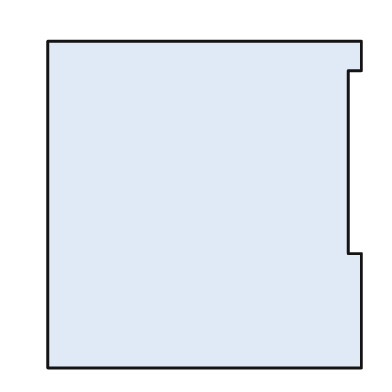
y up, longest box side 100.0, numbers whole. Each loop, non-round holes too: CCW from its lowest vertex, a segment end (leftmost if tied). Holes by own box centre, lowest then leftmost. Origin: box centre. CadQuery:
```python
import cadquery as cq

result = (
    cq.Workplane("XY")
    .moveTo(-48.0, -50.0)
    .lineTo(48.0, -50.0)
    .lineTo(48.0, -15.0)
    .lineTo(44.0, -15.0)
    .lineTo(44.0, 41.0)
    .lineTo(48.0, 41.0)
    .lineTo(48.0, 50.0)
    .lineTo(-48.0, 50.0)
    .close()
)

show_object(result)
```